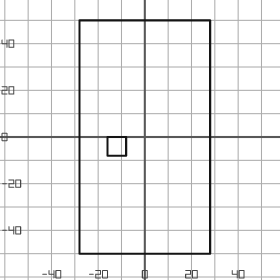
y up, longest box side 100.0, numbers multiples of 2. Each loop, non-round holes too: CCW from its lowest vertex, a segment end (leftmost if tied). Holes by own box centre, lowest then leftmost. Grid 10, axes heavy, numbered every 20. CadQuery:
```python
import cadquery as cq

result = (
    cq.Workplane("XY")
    .moveTo(-28.0, -50.0)
    .lineTo(28.0, -50.0)
    .lineTo(28.0, 50.0)
    .lineTo(-28.0, 50.0)
    .close()
    .moveTo(-16.0, -8.0)
    .lineTo(-8.0, -8.0)
    .lineTo(-8.0, 0.0)
    .lineTo(-16.0, 0.0)
    .close()
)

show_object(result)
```